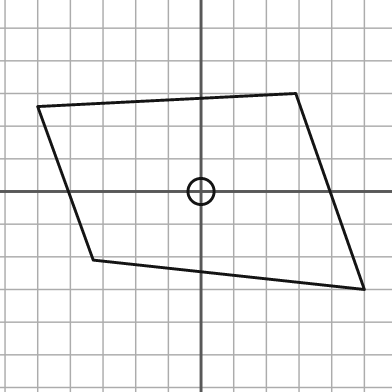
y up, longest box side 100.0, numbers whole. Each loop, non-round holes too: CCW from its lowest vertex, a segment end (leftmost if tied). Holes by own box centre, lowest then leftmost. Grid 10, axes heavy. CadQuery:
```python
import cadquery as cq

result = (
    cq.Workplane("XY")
    .moveTo(50.0, -30.0)
    .lineTo(29.0, 30.0)
    .lineTo(-50.0, 26.0)
    .lineTo(-33.0, -21.0)
    .close()
    .moveTo(0.0, 0.0)
    .circle(4.0)
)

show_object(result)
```